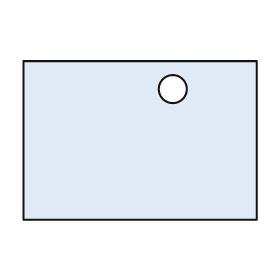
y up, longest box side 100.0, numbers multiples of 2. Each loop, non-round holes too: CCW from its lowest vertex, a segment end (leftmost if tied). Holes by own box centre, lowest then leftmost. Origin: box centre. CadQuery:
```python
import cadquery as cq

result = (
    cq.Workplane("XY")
    .moveTo(-50.0, -34.0)
    .lineTo(50.0, -34.0)
    .lineTo(50.0, 34.0)
    .lineTo(-50.0, 34.0)
    .close()
    .moveTo(14.0, 22.0)
    .circle(6.0)
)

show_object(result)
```